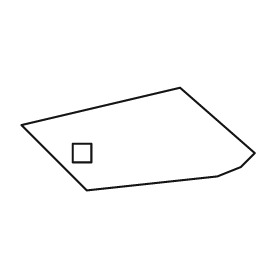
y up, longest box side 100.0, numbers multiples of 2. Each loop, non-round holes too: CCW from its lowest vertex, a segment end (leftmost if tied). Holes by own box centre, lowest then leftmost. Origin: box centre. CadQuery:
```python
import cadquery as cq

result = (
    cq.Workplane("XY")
    .moveTo(-22.0, -22.0)
    .lineTo(34.0, -16.0)
    .lineTo(44.0, -12.0)
    .lineTo(50.0, -6.0)
    .lineTo(18.0, 22.0)
    .lineTo(-50.0, 6.0)
    .close()
    .moveTo(-28.0, -10.0)
    .lineTo(-20.0, -10.0)
    .lineTo(-20.0, -2.0)
    .lineTo(-28.0, -2.0)
    .close()
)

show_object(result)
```